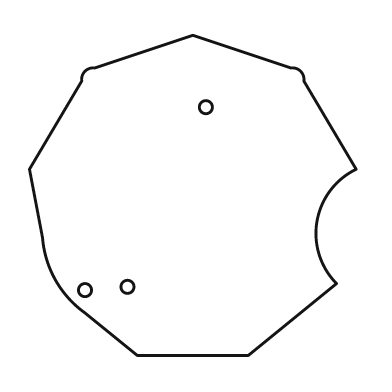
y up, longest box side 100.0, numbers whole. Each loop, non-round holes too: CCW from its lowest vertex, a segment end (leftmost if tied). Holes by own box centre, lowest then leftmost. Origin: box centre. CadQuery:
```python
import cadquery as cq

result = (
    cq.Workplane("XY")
    .moveTo(-17.0, -49.0)
    .lineTo(17.0, -49.0)
    .lineTo(44.0, -27.0)
    .threePointArc((38.0, -8.0), (50.0, 8.0))
    .lineTo(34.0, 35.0)
    .threePointArc((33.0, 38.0), (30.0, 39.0))
    .lineTo(0.0, 49.0)
    .lineTo(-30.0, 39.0)
    .threePointArc((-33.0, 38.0), (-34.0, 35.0))
    .lineTo(-50.0, 8.0)
    .lineTo(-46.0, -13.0)
    .threePointArc((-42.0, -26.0), (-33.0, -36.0))
    .close()
    .moveTo(-33.0, -29.0)
    .circle(2.0)
    .moveTo(-20.0, -28.0)
    .circle(2.0)
    .moveTo(4.0, 27.0)
    .circle(2.0)
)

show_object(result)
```